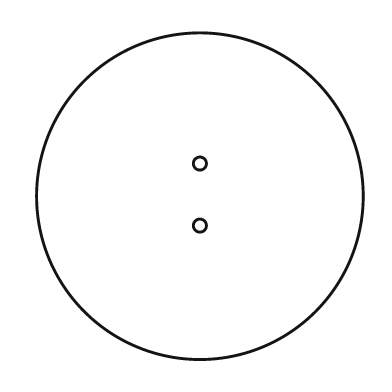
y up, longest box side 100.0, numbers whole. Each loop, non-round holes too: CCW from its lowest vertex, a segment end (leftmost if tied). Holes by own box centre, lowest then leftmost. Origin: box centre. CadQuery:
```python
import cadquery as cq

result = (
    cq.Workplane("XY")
    .moveTo(0.0, 0.0)
    .circle(50.0)
    .moveTo(0.0, -9.0)
    .circle(2.0)
    .moveTo(0.0, 10.0)
    .circle(2.0)
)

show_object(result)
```